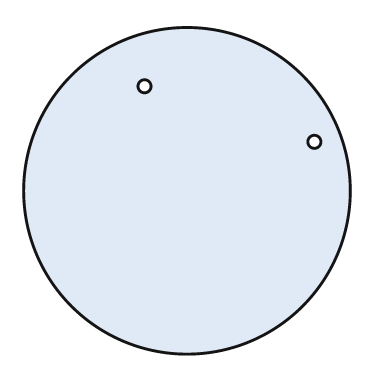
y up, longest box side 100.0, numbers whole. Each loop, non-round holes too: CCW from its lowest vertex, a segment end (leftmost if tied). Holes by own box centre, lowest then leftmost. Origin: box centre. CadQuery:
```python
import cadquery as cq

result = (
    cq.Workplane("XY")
    .moveTo(0.0, 0.0)
    .circle(50.0)
    .moveTo(39.0, 15.0)
    .circle(2.0)
    .moveTo(-13.0, 32.0)
    .circle(2.0)
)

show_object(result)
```